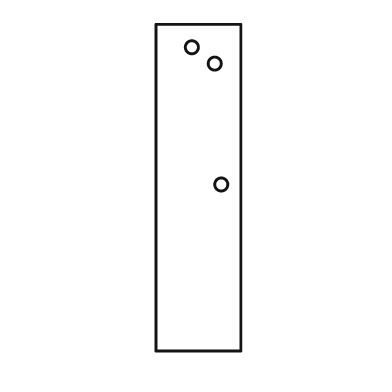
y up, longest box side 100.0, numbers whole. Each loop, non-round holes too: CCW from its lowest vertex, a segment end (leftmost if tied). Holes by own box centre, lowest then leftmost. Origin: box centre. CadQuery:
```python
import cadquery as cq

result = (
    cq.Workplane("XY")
    .moveTo(-13.0, -50.0)
    .lineTo(13.0, -50.0)
    .lineTo(13.0, 50.0)
    .lineTo(-13.0, 50.0)
    .close()
    .moveTo(7.0, 1.0)
    .circle(2.0)
    .moveTo(5.0, 38.0)
    .circle(2.0)
    .moveTo(-2.0, 43.0)
    .circle(2.0)
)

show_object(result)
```